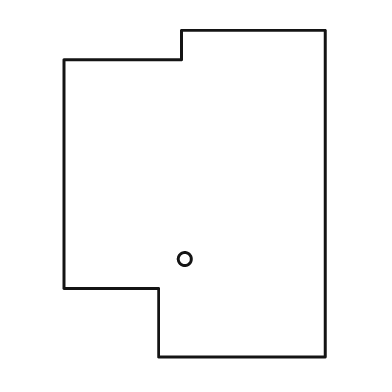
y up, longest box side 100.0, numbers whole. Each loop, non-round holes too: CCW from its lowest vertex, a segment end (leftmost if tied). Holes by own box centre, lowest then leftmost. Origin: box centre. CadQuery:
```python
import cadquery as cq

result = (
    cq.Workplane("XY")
    .moveTo(-11.0, -50.0)
    .lineTo(40.0, -50.0)
    .lineTo(40.0, 50.0)
    .lineTo(-4.0, 50.0)
    .lineTo(-4.0, 41.0)
    .lineTo(-40.0, 41.0)
    .lineTo(-40.0, -29.0)
    .lineTo(-11.0, -29.0)
    .close()
    .moveTo(-3.0, -20.0)
    .circle(2.0)
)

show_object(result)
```